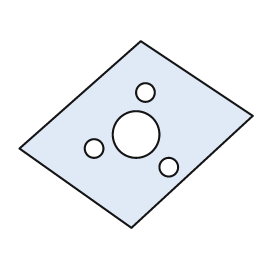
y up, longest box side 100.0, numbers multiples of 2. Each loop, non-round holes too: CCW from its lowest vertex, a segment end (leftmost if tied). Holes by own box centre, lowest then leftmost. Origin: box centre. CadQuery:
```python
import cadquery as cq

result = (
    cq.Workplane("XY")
    .moveTo(-2.0, -40.0)
    .lineTo(50.0, 8.0)
    .lineTo(2.0, 40.0)
    .lineTo(-50.0, -6.0)
    .close()
    .moveTo(14.0, -14.0)
    .circle(4.0)
    .moveTo(-18.0, -6.0)
    .circle(4.0)
    .moveTo(0.0, 0.0)
    .circle(10.0)
    .moveTo(4.0, 18.0)
    .circle(4.0)
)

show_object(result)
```